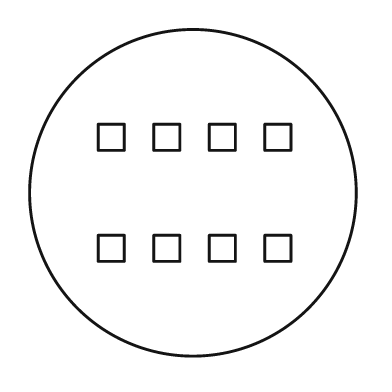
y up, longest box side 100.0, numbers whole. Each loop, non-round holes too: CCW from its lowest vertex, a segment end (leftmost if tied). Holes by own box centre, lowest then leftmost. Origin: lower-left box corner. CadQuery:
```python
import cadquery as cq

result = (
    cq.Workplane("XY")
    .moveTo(50.0, 50.0)
    .circle(50.0)
    .moveTo(21.0, 29.0)
    .lineTo(29.0, 29.0)
    .lineTo(29.0, 37.0)
    .lineTo(21.0, 37.0)
    .close()
    .moveTo(38.0, 29.0)
    .lineTo(46.0, 29.0)
    .lineTo(46.0, 37.0)
    .lineTo(38.0, 37.0)
    .close()
    .moveTo(55.0, 29.0)
    .lineTo(63.0, 29.0)
    .lineTo(63.0, 37.0)
    .lineTo(55.0, 37.0)
    .close()
    .moveTo(72.0, 29.0)
    .lineTo(80.0, 29.0)
    .lineTo(80.0, 37.0)
    .lineTo(72.0, 37.0)
    .close()
    .moveTo(21.0, 63.0)
    .lineTo(29.0, 63.0)
    .lineTo(29.0, 71.0)
    .lineTo(21.0, 71.0)
    .close()
    .moveTo(38.0, 63.0)
    .lineTo(46.0, 63.0)
    .lineTo(46.0, 71.0)
    .lineTo(38.0, 71.0)
    .close()
    .moveTo(55.0, 63.0)
    .lineTo(63.0, 63.0)
    .lineTo(63.0, 71.0)
    .lineTo(55.0, 71.0)
    .close()
    .moveTo(72.0, 63.0)
    .lineTo(80.0, 63.0)
    .lineTo(80.0, 71.0)
    .lineTo(72.0, 71.0)
    .close()
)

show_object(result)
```